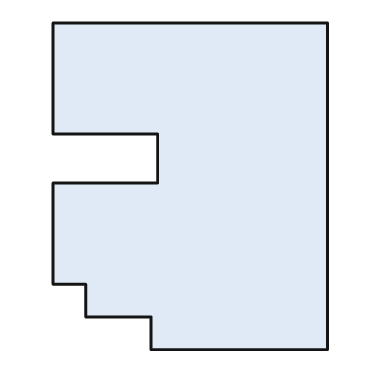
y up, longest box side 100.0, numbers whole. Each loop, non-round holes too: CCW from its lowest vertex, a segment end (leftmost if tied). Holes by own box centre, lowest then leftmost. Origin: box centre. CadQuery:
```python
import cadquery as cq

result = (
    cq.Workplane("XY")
    .moveTo(-12.0, -50.0)
    .lineTo(42.0, -50.0)
    .lineTo(42.0, 50.0)
    .lineTo(-42.0, 50.0)
    .lineTo(-42.0, 16.0)
    .lineTo(-10.0, 16.0)
    .lineTo(-10.0, 1.0)
    .lineTo(-42.0, 1.0)
    .lineTo(-42.0, -30.0)
    .lineTo(-32.0, -30.0)
    .lineTo(-32.0, -40.0)
    .lineTo(-12.0, -40.0)
    .close()
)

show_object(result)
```